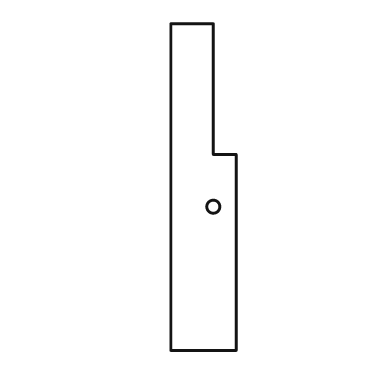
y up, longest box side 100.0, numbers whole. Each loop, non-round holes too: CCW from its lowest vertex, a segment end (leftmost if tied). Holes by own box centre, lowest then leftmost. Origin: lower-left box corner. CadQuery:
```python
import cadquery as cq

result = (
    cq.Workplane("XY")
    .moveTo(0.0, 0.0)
    .lineTo(20.0, 0.0)
    .lineTo(20.0, 60.0)
    .lineTo(13.0, 60.0)
    .lineTo(13.0, 100.0)
    .lineTo(0.0, 100.0)
    .close()
    .moveTo(13.0, 44.0)
    .circle(2.0)
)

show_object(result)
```